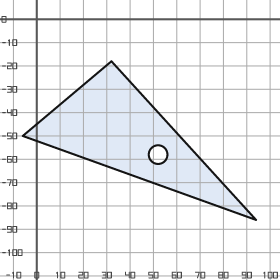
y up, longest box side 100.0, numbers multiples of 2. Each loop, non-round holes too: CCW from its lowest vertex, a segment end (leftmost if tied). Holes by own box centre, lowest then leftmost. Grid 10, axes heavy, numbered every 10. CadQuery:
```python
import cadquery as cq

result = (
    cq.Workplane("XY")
    .moveTo(94.0, -86.0)
    .lineTo(32.0, -18.0)
    .lineTo(-6.0, -50.0)
    .close()
    .moveTo(52.0, -58.0)
    .circle(4.0)
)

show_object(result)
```